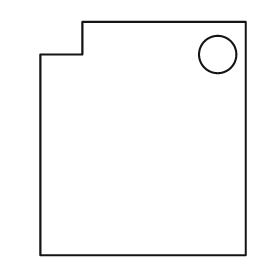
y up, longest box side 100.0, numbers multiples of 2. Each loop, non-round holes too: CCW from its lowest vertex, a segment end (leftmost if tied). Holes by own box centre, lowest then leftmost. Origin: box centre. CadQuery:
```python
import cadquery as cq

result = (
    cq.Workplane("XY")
    .moveTo(-44.0, -50.0)
    .lineTo(44.0, -50.0)
    .lineTo(44.0, 50.0)
    .lineTo(-26.0, 50.0)
    .lineTo(-26.0, 36.0)
    .lineTo(-44.0, 36.0)
    .close()
    .moveTo(32.0, 36.0)
    .circle(8.0)
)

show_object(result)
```